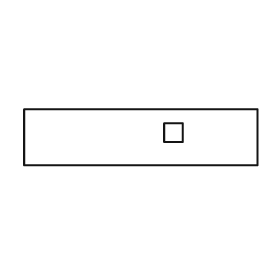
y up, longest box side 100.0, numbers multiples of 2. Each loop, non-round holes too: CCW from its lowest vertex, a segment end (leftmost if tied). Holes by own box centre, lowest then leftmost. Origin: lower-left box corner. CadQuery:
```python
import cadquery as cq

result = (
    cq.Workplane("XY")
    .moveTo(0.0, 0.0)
    .lineTo(100.0, 0.0)
    .lineTo(100.0, 24.0)
    .lineTo(0.0, 24.0)
    .close()
    .moveTo(60.0, 10.0)
    .lineTo(68.0, 10.0)
    .lineTo(68.0, 18.0)
    .lineTo(60.0, 18.0)
    .close()
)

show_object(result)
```